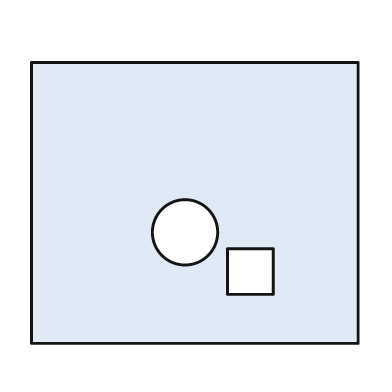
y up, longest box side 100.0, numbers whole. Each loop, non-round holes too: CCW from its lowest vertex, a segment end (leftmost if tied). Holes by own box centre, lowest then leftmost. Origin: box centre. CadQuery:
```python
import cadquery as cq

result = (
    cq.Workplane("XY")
    .moveTo(-50.0, -43.0)
    .lineTo(50.0, -43.0)
    .lineTo(50.0, 43.0)
    .lineTo(-50.0, 43.0)
    .close()
    .moveTo(10.0, -28.0)
    .lineTo(24.0, -28.0)
    .lineTo(24.0, -14.0)
    .lineTo(10.0, -14.0)
    .close()
    .moveTo(-3.0, -9.0)
    .circle(10.0)
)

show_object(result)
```